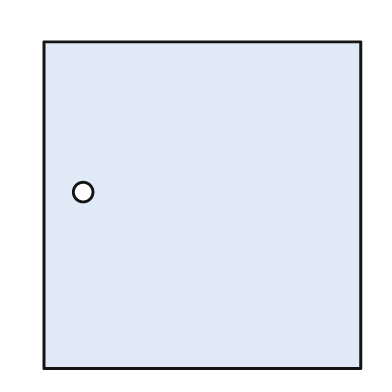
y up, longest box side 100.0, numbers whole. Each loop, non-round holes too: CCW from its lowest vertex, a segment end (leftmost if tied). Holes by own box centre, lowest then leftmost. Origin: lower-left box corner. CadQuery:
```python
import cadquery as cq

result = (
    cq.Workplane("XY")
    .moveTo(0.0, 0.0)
    .lineTo(97.0, 0.0)
    .lineTo(97.0, 100.0)
    .lineTo(0.0, 100.0)
    .close()
    .moveTo(12.0, 54.0)
    .circle(3.0)
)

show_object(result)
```